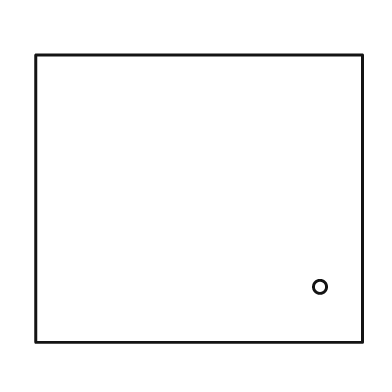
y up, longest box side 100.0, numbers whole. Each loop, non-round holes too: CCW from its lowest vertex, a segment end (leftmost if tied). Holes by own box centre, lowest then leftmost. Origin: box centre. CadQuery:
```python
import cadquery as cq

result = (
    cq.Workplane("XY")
    .moveTo(-50.0, -44.0)
    .lineTo(50.0, -44.0)
    .lineTo(50.0, 44.0)
    .lineTo(-50.0, 44.0)
    .close()
    .moveTo(37.0, -27.0)
    .circle(2.0)
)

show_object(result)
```